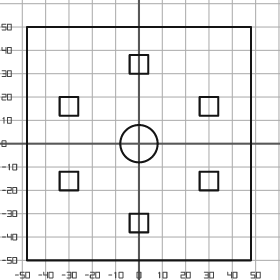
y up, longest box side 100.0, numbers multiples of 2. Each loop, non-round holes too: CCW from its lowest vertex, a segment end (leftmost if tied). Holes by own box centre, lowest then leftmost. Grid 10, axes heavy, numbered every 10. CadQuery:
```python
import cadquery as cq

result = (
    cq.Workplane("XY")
    .moveTo(-48.0, -50.0)
    .lineTo(48.0, -50.0)
    .lineTo(48.0, 50.0)
    .lineTo(-48.0, 50.0)
    .close()
    .moveTo(-4.0, -38.0)
    .lineTo(4.0, -38.0)
    .lineTo(4.0, -30.0)
    .lineTo(-4.0, -30.0)
    .close()
    .moveTo(-34.0, -20.0)
    .lineTo(-26.0, -20.0)
    .lineTo(-26.0, -12.0)
    .lineTo(-34.0, -12.0)
    .close()
    .moveTo(26.0, -20.0)
    .lineTo(34.0, -20.0)
    .lineTo(34.0, -12.0)
    .lineTo(26.0, -12.0)
    .close()
    .moveTo(0.0, 0.0)
    .circle(8.0)
    .moveTo(-34.0, 12.0)
    .lineTo(-26.0, 12.0)
    .lineTo(-26.0, 20.0)
    .lineTo(-34.0, 20.0)
    .close()
    .moveTo(26.0, 12.0)
    .lineTo(34.0, 12.0)
    .lineTo(34.0, 20.0)
    .lineTo(26.0, 20.0)
    .close()
    .moveTo(-4.0, 30.0)
    .lineTo(4.0, 30.0)
    .lineTo(4.0, 38.0)
    .lineTo(-4.0, 38.0)
    .close()
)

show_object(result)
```